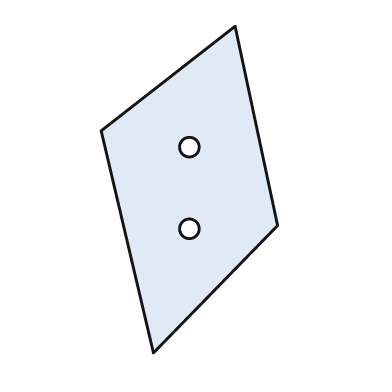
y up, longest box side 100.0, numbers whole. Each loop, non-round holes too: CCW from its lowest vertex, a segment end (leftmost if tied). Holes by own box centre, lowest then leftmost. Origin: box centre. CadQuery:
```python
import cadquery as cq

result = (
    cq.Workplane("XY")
    .moveTo(-11.0, -50.0)
    .lineTo(27.0, -11.0)
    .lineTo(14.0, 50.0)
    .lineTo(-27.0, 18.0)
    .close()
    .moveTo(0.0, -12.0)
    .circle(3.0)
    .moveTo(0.0, 13.0)
    .circle(3.0)
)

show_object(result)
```